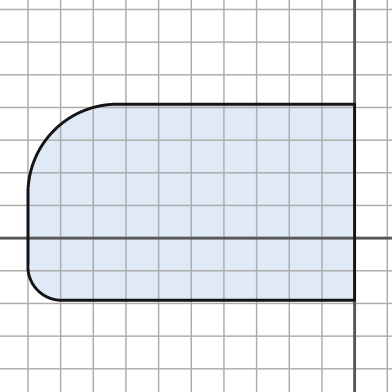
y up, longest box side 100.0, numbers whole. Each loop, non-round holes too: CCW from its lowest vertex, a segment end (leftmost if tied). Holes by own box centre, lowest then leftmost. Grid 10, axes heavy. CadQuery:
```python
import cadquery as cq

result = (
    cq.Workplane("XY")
    .moveTo(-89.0, -19.0)
    .lineTo(0.0, -19.0)
    .lineTo(0.0, 41.0)
    .lineTo(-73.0, 41.0)
    .threePointArc((-92.0, 33.0), (-100.0, 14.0))
    .lineTo(-100.0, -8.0)
    .threePointArc((-97.0, -16.0), (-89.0, -19.0))
    .close()
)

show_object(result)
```